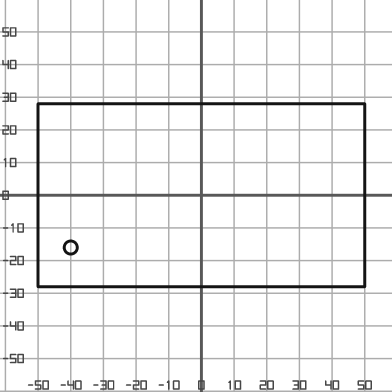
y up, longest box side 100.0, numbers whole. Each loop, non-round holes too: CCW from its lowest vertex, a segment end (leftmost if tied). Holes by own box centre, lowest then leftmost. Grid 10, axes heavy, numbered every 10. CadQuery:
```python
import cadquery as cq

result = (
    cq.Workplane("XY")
    .moveTo(-50.0, -28.0)
    .lineTo(50.0, -28.0)
    .lineTo(50.0, 28.0)
    .lineTo(-50.0, 28.0)
    .close()
    .moveTo(-40.0, -16.0)
    .circle(2.0)
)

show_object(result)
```